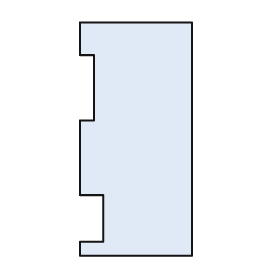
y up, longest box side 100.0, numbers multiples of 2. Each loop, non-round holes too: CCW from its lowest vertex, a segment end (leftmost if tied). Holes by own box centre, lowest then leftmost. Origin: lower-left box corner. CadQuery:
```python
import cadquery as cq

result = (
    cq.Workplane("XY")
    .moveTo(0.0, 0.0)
    .lineTo(48.0, 0.0)
    .lineTo(48.0, 100.0)
    .lineTo(0.0, 100.0)
    .lineTo(0.0, 86.0)
    .lineTo(6.0, 86.0)
    .lineTo(6.0, 58.0)
    .lineTo(0.0, 58.0)
    .lineTo(0.0, 26.0)
    .lineTo(10.0, 26.0)
    .lineTo(10.0, 6.0)
    .lineTo(0.0, 6.0)
    .close()
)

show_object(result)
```